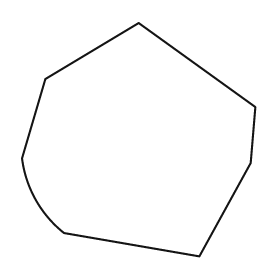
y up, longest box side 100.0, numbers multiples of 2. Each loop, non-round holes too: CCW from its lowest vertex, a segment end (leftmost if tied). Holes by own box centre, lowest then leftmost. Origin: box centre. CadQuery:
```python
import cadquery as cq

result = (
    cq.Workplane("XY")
    .moveTo(26.0, -50.0)
    .lineTo(48.0, -10.0)
    .lineTo(50.0, 14.0)
    .lineTo(0.0, 50.0)
    .lineTo(-40.0, 26.0)
    .lineTo(-50.0, -8.0)
    .threePointArc((-44.0, -26.0), (-32.0, -40.0))
    .close()
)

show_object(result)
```